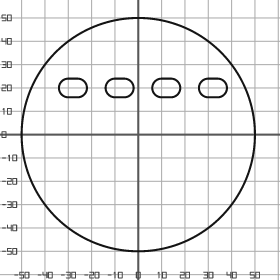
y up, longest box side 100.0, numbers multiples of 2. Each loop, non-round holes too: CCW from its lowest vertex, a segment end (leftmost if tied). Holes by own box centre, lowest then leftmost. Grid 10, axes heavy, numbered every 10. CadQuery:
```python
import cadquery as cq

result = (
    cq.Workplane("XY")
    .moveTo(0.0, 0.0)
    .circle(50.0)
    .moveTo(-30.0, 16.0)
    .lineTo(-26.0, 16.0)
    .threePointArc((-22.0, 20.0), (-26.0, 24.0))
    .lineTo(-30.0, 24.0)
    .threePointArc((-34.0, 20.0), (-30.0, 16.0))
    .close()
    .moveTo(-10.0, 16.0)
    .lineTo(-6.0, 16.0)
    .threePointArc((-2.0, 20.0), (-6.0, 24.0))
    .lineTo(-10.0, 24.0)
    .threePointArc((-14.0, 20.0), (-10.0, 16.0))
    .close()
    .moveTo(10.0, 16.0)
    .lineTo(14.0, 16.0)
    .threePointArc((18.0, 20.0), (14.0, 24.0))
    .lineTo(10.0, 24.0)
    .threePointArc((6.0, 20.0), (10.0, 16.0))
    .close()
    .moveTo(30.0, 16.0)
    .lineTo(34.0, 16.0)
    .threePointArc((38.0, 20.0), (34.0, 24.0))
    .lineTo(30.0, 24.0)
    .threePointArc((26.0, 20.0), (30.0, 16.0))
    .close()
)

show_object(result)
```